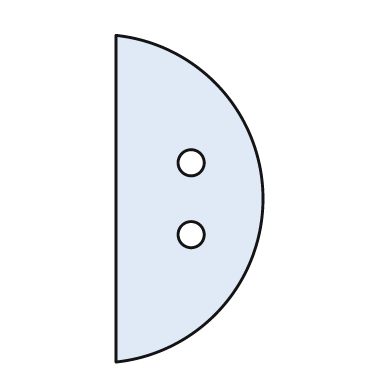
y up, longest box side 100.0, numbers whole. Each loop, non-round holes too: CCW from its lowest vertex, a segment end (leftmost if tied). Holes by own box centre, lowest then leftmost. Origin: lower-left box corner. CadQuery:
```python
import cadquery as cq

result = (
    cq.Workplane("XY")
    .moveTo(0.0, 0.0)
    .threePointArc((45.0, 50.0), (0.0, 100.0))
    .close()
    .moveTo(23.0, 39.0)
    .circle(4.0)
    .moveTo(23.0, 61.0)
    .circle(4.0)
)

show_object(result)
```